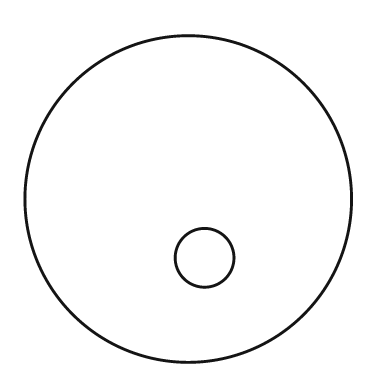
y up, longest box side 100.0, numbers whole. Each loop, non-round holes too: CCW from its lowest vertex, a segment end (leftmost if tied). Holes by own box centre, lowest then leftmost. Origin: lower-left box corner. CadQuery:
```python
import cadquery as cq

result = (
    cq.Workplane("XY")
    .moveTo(50.0, 50.0)
    .circle(50.0)
    .moveTo(55.0, 32.0)
    .circle(9.0)
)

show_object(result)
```